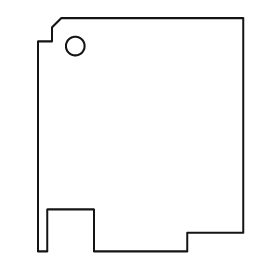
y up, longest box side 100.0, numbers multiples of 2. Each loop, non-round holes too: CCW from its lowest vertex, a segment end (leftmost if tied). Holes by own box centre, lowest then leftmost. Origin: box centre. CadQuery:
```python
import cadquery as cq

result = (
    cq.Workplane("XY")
    .moveTo(-44.0, -50.0)
    .lineTo(-40.0, -50.0)
    .lineTo(-40.0, -32.0)
    .lineTo(-20.0, -32.0)
    .lineTo(-20.0, -50.0)
    .lineTo(20.0, -50.0)
    .lineTo(20.0, -42.0)
    .lineTo(44.0, -42.0)
    .lineTo(44.0, 50.0)
    .lineTo(-34.0, 50.0)
    .lineTo(-38.0, 46.0)
    .lineTo(-38.0, 40.0)
    .lineTo(-44.0, 40.0)
    .close()
    .moveTo(-28.0, 38.0)
    .circle(4.0)
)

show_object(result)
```